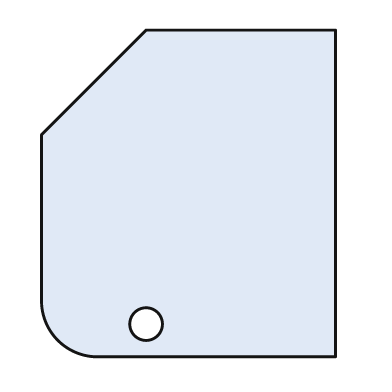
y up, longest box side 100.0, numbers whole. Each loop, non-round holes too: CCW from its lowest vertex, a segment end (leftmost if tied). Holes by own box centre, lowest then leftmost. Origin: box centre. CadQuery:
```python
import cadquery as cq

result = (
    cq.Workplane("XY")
    .moveTo(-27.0, -50.0)
    .lineTo(45.0, -50.0)
    .lineTo(45.0, 50.0)
    .lineTo(-13.0, 50.0)
    .lineTo(-45.0, 18.0)
    .lineTo(-45.0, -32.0)
    .threePointArc((-40.0, -45.0), (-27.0, -50.0))
    .close()
    .moveTo(-13.0, -40.0)
    .circle(5.0)
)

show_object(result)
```